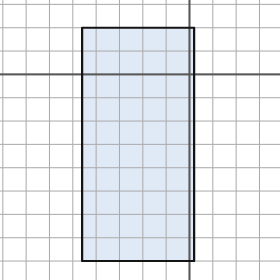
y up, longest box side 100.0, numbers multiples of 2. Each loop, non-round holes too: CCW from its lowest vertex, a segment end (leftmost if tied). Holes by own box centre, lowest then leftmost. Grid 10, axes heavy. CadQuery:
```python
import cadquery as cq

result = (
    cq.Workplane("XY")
    .moveTo(-46.0, -80.0)
    .lineTo(2.0, -80.0)
    .lineTo(2.0, 20.0)
    .lineTo(-46.0, 20.0)
    .close()
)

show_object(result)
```